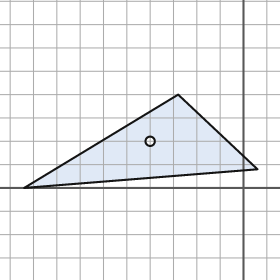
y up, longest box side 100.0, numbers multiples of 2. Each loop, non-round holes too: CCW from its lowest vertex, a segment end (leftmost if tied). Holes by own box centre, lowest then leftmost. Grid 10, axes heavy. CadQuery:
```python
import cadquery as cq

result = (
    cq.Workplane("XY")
    .moveTo(-94.0, 0.0)
    .lineTo(6.0, 8.0)
    .lineTo(-28.0, 40.0)
    .close()
    .moveTo(-40.0, 20.0)
    .circle(2.0)
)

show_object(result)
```